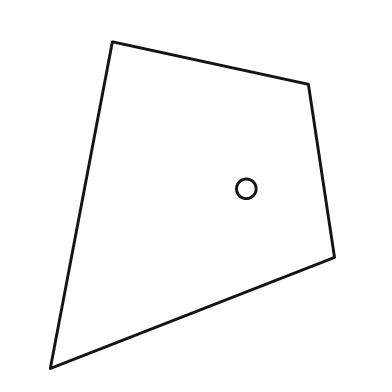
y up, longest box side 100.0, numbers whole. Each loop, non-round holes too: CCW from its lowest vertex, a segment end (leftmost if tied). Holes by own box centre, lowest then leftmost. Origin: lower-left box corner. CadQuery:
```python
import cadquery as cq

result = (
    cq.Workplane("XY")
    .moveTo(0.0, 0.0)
    .lineTo(87.0, 34.0)
    .lineTo(79.0, 87.0)
    .lineTo(19.0, 100.0)
    .close()
    .moveTo(60.0, 55.0)
    .circle(3.0)
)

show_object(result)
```